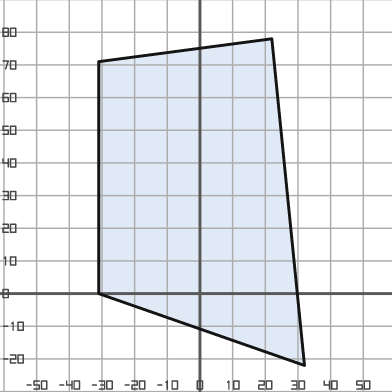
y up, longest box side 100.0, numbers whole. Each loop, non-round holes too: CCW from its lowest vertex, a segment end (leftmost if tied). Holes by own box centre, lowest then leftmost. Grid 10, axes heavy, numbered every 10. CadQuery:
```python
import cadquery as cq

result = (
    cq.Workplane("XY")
    .moveTo(32.0, -22.0)
    .lineTo(22.0, 78.0)
    .lineTo(-31.0, 71.0)
    .lineTo(-31.0, 0.0)
    .close()
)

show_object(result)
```